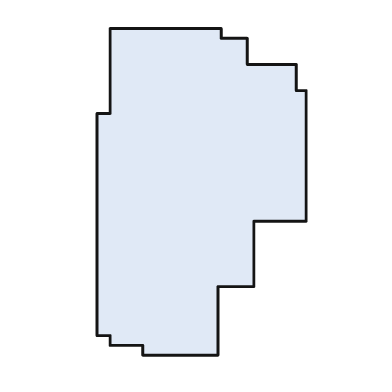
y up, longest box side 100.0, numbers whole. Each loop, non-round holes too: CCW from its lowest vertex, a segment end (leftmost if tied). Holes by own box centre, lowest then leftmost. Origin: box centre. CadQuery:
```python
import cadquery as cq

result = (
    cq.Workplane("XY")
    .moveTo(-18.0, -50.0)
    .lineTo(5.0, -50.0)
    .lineTo(5.0, -29.0)
    .lineTo(16.0, -29.0)
    .lineTo(16.0, -9.0)
    .lineTo(32.0, -9.0)
    .lineTo(32.0, 31.0)
    .lineTo(29.0, 31.0)
    .lineTo(29.0, 39.0)
    .lineTo(14.0, 39.0)
    .lineTo(14.0, 47.0)
    .lineTo(6.0, 47.0)
    .lineTo(6.0, 50.0)
    .lineTo(-28.0, 50.0)
    .lineTo(-28.0, 24.0)
    .lineTo(-32.0, 24.0)
    .lineTo(-32.0, -44.0)
    .lineTo(-28.0, -44.0)
    .lineTo(-28.0, -47.0)
    .lineTo(-18.0, -47.0)
    .close()
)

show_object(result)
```